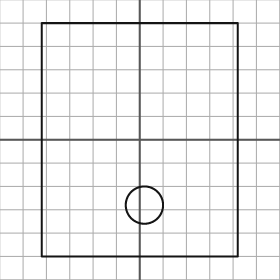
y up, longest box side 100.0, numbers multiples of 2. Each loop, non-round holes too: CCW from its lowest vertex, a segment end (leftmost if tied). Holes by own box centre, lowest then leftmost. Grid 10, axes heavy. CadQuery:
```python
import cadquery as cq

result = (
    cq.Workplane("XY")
    .moveTo(-42.0, -50.0)
    .lineTo(42.0, -50.0)
    .lineTo(42.0, 50.0)
    .lineTo(-42.0, 50.0)
    .close()
    .moveTo(2.0, -28.0)
    .circle(8.0)
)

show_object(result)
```